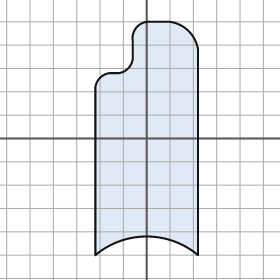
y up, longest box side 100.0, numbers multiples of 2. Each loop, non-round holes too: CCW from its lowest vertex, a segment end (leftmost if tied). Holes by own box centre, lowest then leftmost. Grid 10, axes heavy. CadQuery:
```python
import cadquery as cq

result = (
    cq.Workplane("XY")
    .moveTo(-22.0, -50.0)
    .threePointArc((0.0, -42.0), (22.0, -50.0))
    .lineTo(22.0, 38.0)
    .threePointArc((18.0, 46.0), (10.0, 50.0))
    .lineTo(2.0, 50.0)
    .threePointArc((-4.0, 48.0), (-6.0, 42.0))
    .lineTo(-6.0, 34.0)
    .threePointArc((-8.0, 30.0), (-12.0, 28.0))
    .lineTo(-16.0, 28.0)
    .threePointArc((-20.0, 26.0), (-22.0, 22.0))
    .close()
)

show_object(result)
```